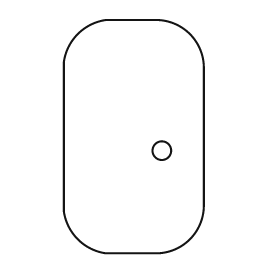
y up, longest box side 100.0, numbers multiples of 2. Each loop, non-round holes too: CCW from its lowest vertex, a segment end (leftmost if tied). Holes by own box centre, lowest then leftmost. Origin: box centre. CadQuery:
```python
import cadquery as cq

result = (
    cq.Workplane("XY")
    .moveTo(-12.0, -50.0)
    .lineTo(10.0, -50.0)
    .threePointArc((24.0, -44.0), (30.0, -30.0))
    .lineTo(30.0, 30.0)
    .threePointArc((24.0, 44.0), (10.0, 50.0))
    .lineTo(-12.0, 50.0)
    .threePointArc((-24.0, 44.0), (-30.0, 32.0))
    .lineTo(-30.0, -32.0)
    .threePointArc((-24.0, -44.0), (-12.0, -50.0))
    .close()
    .moveTo(12.0, -6.0)
    .circle(4.0)
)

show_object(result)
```